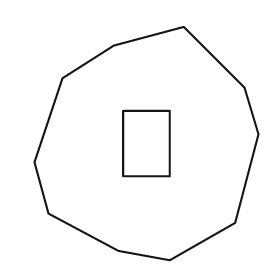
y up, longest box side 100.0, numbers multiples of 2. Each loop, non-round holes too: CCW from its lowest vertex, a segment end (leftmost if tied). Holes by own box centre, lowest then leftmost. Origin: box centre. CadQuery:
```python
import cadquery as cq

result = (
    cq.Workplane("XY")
    .moveTo(10.0, -50.0)
    .lineTo(38.0, -34.0)
    .lineTo(48.0, 4.0)
    .lineTo(42.0, 24.0)
    .lineTo(16.0, 50.0)
    .lineTo(-14.0, 42.0)
    .lineTo(-36.0, 28.0)
    .lineTo(-48.0, -8.0)
    .lineTo(-42.0, -30.0)
    .lineTo(-12.0, -46.0)
    .close()
    .moveTo(-10.0, -14.0)
    .lineTo(10.0, -14.0)
    .lineTo(10.0, 14.0)
    .lineTo(-10.0, 14.0)
    .close()
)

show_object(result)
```